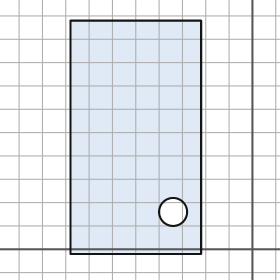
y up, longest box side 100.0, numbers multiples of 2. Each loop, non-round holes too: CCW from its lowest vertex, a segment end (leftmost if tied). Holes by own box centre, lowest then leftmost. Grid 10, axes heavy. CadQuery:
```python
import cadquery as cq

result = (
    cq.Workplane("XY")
    .moveTo(-78.0, -2.0)
    .lineTo(-22.0, -2.0)
    .lineTo(-22.0, 98.0)
    .lineTo(-78.0, 98.0)
    .close()
    .moveTo(-34.0, 16.0)
    .circle(6.0)
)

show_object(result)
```